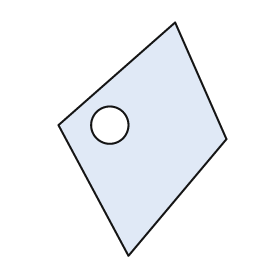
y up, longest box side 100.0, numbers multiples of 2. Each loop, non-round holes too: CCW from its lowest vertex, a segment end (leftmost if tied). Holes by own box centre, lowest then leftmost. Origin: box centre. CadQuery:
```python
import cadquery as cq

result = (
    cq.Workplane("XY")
    .moveTo(-6.0, -50.0)
    .lineTo(36.0, 0.0)
    .lineTo(14.0, 50.0)
    .lineTo(-36.0, 6.0)
    .close()
    .moveTo(-14.0, 6.0)
    .circle(8.0)
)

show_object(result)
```